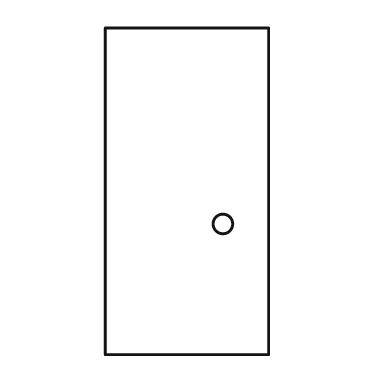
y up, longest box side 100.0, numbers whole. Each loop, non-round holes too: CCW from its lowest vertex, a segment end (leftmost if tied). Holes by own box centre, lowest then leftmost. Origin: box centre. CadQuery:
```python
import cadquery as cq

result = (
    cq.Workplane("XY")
    .moveTo(-25.0, -50.0)
    .lineTo(25.0, -50.0)
    .lineTo(25.0, 50.0)
    .lineTo(-25.0, 50.0)
    .close()
    .moveTo(11.0, -10.0)
    .circle(3.0)
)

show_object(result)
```